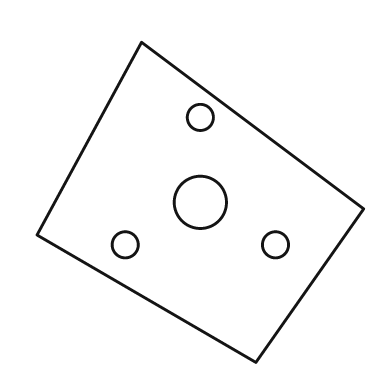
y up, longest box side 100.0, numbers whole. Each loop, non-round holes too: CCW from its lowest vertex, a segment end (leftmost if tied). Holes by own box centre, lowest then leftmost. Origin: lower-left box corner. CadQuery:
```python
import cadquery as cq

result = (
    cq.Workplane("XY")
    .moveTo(67.0, 0.0)
    .lineTo(100.0, 47.0)
    .lineTo(32.0, 98.0)
    .lineTo(0.0, 39.0)
    .close()
    .moveTo(27.0, 36.0)
    .circle(4.0)
    .moveTo(73.0, 36.0)
    .circle(4.0)
    .moveTo(50.0, 49.0)
    .circle(8.0)
    .moveTo(50.0, 75.0)
    .circle(4.0)
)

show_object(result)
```